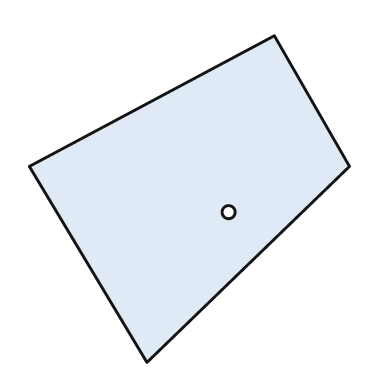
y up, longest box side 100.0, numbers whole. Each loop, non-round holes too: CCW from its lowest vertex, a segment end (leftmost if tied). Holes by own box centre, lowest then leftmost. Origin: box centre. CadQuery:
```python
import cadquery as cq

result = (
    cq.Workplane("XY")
    .moveTo(-13.0, -50.0)
    .lineTo(49.0, 10.0)
    .lineTo(26.0, 50.0)
    .lineTo(-49.0, 10.0)
    .close()
    .moveTo(12.0, -4.0)
    .circle(2.0)
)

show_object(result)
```